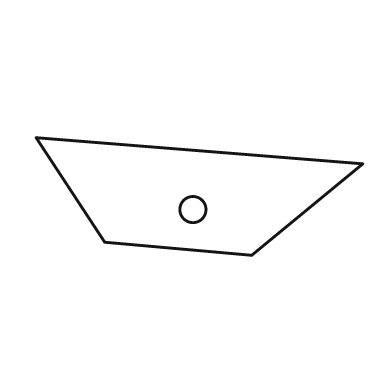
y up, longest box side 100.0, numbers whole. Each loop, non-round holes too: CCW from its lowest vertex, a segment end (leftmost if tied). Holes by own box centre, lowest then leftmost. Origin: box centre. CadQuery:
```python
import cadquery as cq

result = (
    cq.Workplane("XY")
    .moveTo(16.0, -18.0)
    .lineTo(50.0, 10.0)
    .lineTo(-50.0, 18.0)
    .lineTo(-29.0, -14.0)
    .close()
    .moveTo(-2.0, -4.0)
    .circle(4.0)
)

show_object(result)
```